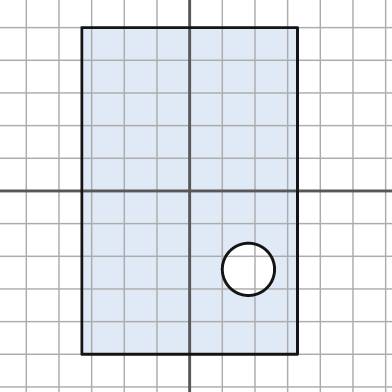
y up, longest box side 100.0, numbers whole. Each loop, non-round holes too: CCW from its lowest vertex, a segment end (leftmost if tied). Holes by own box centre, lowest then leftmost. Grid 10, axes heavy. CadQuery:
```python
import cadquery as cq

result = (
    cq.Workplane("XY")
    .moveTo(-33.0, -50.0)
    .lineTo(33.0, -50.0)
    .lineTo(33.0, 50.0)
    .lineTo(-33.0, 50.0)
    .close()
    .moveTo(18.0, -24.0)
    .circle(8.0)
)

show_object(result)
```